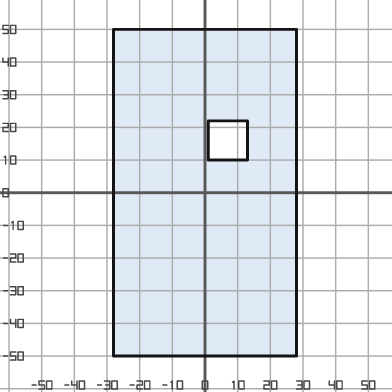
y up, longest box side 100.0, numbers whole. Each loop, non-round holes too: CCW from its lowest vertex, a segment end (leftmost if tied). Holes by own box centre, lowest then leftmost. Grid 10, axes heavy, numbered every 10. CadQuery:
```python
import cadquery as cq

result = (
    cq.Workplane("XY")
    .moveTo(-28.0, -50.0)
    .lineTo(28.0, -50.0)
    .lineTo(28.0, 50.0)
    .lineTo(-28.0, 50.0)
    .close()
    .moveTo(1.0, 10.0)
    .lineTo(13.0, 10.0)
    .lineTo(13.0, 22.0)
    .lineTo(1.0, 22.0)
    .close()
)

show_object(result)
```